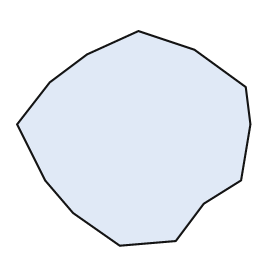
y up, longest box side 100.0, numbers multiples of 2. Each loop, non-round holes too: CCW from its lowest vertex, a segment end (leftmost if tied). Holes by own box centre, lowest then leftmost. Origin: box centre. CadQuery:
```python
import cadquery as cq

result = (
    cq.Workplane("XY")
    .moveTo(-6.0, -46.0)
    .lineTo(18.0, -44.0)
    .lineTo(30.0, -28.0)
    .lineTo(46.0, -18.0)
    .lineTo(50.0, 6.0)
    .lineTo(48.0, 22.0)
    .lineTo(26.0, 38.0)
    .lineTo(2.0, 46.0)
    .lineTo(-20.0, 36.0)
    .lineTo(-36.0, 24.0)
    .lineTo(-50.0, 6.0)
    .lineTo(-38.0, -18.0)
    .lineTo(-26.0, -32.0)
    .close()
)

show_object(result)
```